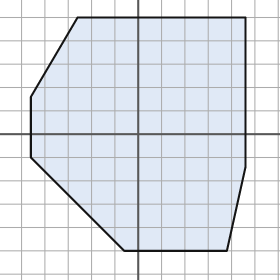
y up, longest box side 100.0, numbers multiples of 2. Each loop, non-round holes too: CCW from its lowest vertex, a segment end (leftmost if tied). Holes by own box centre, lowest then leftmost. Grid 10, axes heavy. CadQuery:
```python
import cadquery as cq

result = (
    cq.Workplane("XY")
    .moveTo(-6.0, -50.0)
    .lineTo(38.0, -50.0)
    .lineTo(46.0, -14.0)
    .lineTo(46.0, 50.0)
    .lineTo(-26.0, 50.0)
    .lineTo(-46.0, 16.0)
    .lineTo(-46.0, -10.0)
    .close()
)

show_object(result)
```